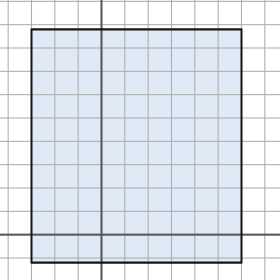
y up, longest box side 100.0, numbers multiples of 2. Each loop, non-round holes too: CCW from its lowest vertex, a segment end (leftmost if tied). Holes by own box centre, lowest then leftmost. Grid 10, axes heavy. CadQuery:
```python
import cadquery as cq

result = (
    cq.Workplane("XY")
    .moveTo(-30.0, -12.0)
    .lineTo(60.0, -12.0)
    .lineTo(60.0, 88.0)
    .lineTo(-30.0, 88.0)
    .close()
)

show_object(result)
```